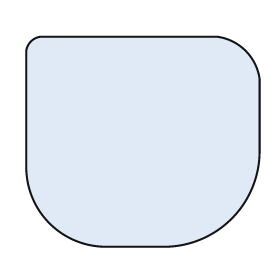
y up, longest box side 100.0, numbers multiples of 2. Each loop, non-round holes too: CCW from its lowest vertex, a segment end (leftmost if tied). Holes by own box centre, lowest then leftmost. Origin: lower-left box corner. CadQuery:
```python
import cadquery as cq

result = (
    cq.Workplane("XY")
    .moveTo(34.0, 0.0)
    .lineTo(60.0, 0.0)
    .threePointArc((88.0, 12.0), (100.0, 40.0))
    .lineTo(100.0, 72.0)
    .threePointArc((94.0, 84.0), (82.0, 90.0))
    .lineTo(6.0, 90.0)
    .threePointArc((2.0, 88.0), (0.0, 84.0))
    .lineTo(0.0, 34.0)
    .threePointArc((10.0, 10.0), (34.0, 0.0))
    .close()
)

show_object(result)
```